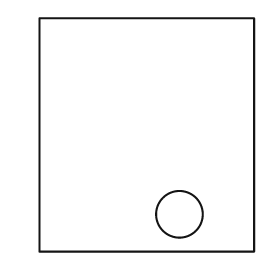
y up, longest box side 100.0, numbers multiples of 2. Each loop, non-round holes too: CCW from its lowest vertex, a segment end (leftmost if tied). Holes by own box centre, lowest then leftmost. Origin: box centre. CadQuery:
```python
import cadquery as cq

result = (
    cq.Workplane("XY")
    .moveTo(-46.0, -50.0)
    .lineTo(46.0, -50.0)
    .lineTo(46.0, 50.0)
    .lineTo(-46.0, 50.0)
    .close()
    .moveTo(14.0, -34.0)
    .circle(10.0)
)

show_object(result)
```